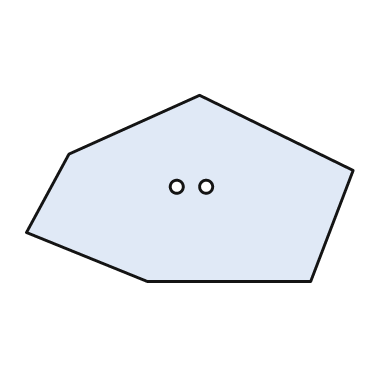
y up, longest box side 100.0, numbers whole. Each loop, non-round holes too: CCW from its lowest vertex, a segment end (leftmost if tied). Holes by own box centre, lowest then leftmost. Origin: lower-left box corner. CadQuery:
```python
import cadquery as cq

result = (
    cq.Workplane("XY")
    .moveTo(37.0, 0.0)
    .lineTo(87.0, 0.0)
    .lineTo(100.0, 34.0)
    .lineTo(53.0, 57.0)
    .lineTo(13.0, 39.0)
    .lineTo(0.0, 15.0)
    .close()
    .moveTo(46.0, 29.0)
    .circle(2.0)
    .moveTo(55.0, 29.0)
    .circle(2.0)
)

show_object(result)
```